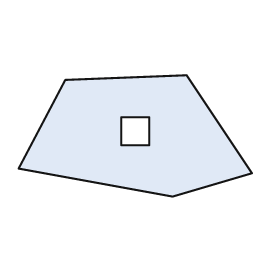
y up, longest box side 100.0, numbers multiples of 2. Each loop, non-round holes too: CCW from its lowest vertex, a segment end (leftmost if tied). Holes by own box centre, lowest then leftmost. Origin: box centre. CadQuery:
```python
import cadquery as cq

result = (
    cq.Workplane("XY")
    .moveTo(16.0, -26.0)
    .lineTo(50.0, -16.0)
    .lineTo(22.0, 26.0)
    .lineTo(-30.0, 24.0)
    .lineTo(-50.0, -14.0)
    .close()
    .moveTo(-6.0, -4.0)
    .lineTo(6.0, -4.0)
    .lineTo(6.0, 8.0)
    .lineTo(-6.0, 8.0)
    .close()
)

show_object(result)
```